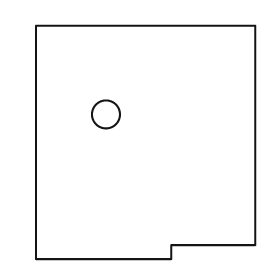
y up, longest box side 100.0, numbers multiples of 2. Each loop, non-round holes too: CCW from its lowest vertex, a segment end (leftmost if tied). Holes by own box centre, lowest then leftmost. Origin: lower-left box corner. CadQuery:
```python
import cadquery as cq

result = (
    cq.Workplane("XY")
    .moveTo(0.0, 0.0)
    .lineTo(58.0, 0.0)
    .lineTo(58.0, 6.0)
    .lineTo(94.0, 6.0)
    .lineTo(94.0, 100.0)
    .lineTo(0.0, 100.0)
    .close()
    .moveTo(30.0, 62.0)
    .circle(6.0)
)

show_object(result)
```